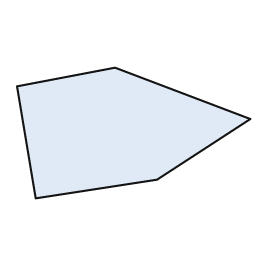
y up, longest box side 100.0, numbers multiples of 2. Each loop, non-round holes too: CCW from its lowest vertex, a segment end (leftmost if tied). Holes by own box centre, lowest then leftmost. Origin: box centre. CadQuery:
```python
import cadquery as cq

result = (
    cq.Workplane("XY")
    .moveTo(-42.0, -28.0)
    .lineTo(10.0, -20.0)
    .lineTo(50.0, 6.0)
    .lineTo(-8.0, 28.0)
    .lineTo(-50.0, 20.0)
    .close()
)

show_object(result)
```